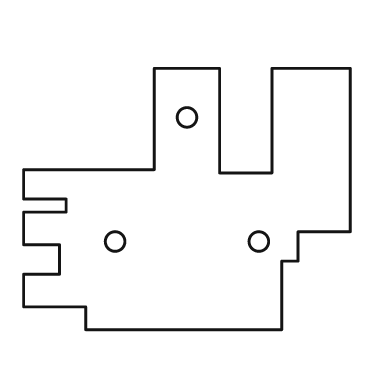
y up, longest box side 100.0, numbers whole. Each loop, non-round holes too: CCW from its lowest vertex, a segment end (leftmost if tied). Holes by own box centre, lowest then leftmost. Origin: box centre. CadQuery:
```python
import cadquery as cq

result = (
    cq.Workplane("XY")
    .moveTo(-31.0, -40.0)
    .lineTo(29.0, -40.0)
    .lineTo(29.0, -19.0)
    .lineTo(34.0, -19.0)
    .lineTo(34.0, -10.0)
    .lineTo(50.0, -10.0)
    .lineTo(50.0, 40.0)
    .lineTo(26.0, 40.0)
    .lineTo(26.0, 8.0)
    .lineTo(10.0, 8.0)
    .lineTo(10.0, 40.0)
    .lineTo(-10.0, 40.0)
    .lineTo(-10.0, 9.0)
    .lineTo(-50.0, 9.0)
    .lineTo(-50.0, 0.0)
    .lineTo(-37.0, 0.0)
    .lineTo(-37.0, -4.0)
    .lineTo(-50.0, -4.0)
    .lineTo(-50.0, -14.0)
    .lineTo(-39.0, -14.0)
    .lineTo(-39.0, -23.0)
    .lineTo(-50.0, -23.0)
    .lineTo(-50.0, -33.0)
    .lineTo(-31.0, -33.0)
    .close()
    .moveTo(-22.0, -13.0)
    .circle(3.0)
    .moveTo(22.0, -13.0)
    .circle(3.0)
    .moveTo(0.0, 25.0)
    .circle(3.0)
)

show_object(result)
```